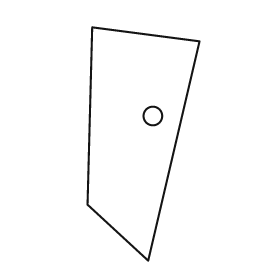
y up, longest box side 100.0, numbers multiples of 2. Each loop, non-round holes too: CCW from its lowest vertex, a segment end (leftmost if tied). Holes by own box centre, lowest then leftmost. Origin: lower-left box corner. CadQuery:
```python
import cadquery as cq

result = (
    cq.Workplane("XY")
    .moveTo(26.0, 0.0)
    .lineTo(48.0, 94.0)
    .lineTo(2.0, 100.0)
    .lineTo(0.0, 24.0)
    .close()
    .moveTo(28.0, 62.0)
    .circle(4.0)
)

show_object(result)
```